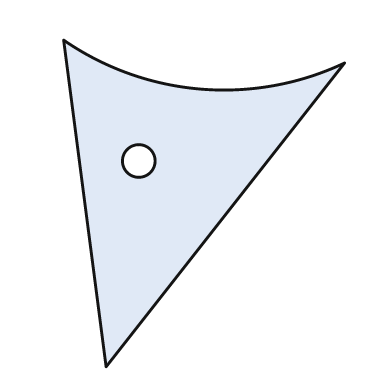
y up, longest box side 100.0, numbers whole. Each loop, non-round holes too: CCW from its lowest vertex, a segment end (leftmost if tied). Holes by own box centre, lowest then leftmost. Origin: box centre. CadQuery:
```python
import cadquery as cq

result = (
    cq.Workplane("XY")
    .moveTo(-30.0, -50.0)
    .lineTo(43.0, 43.0)
    .threePointArc((-1.0, 35.0), (-43.0, 50.0))
    .close()
    .moveTo(-20.0, 13.0)
    .circle(5.0)
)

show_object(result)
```